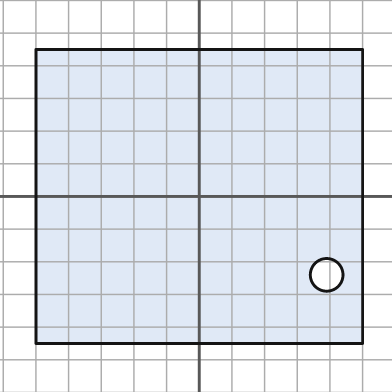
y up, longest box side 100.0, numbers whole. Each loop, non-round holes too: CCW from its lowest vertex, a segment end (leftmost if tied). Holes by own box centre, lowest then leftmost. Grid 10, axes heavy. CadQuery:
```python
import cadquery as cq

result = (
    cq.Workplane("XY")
    .moveTo(-50.0, -45.0)
    .lineTo(50.0, -45.0)
    .lineTo(50.0, 45.0)
    .lineTo(-50.0, 45.0)
    .close()
    .moveTo(39.0, -24.0)
    .circle(5.0)
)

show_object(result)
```